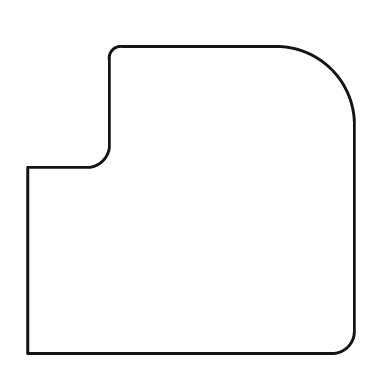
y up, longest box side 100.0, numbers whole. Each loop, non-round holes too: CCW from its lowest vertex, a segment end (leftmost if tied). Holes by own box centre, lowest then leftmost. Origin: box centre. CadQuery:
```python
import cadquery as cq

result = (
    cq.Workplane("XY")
    .moveTo(-50.0, -47.0)
    .lineTo(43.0, -47.0)
    .threePointArc((48.0, -45.0), (50.0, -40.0))
    .lineTo(50.0, 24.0)
    .threePointArc((43.0, 40.0), (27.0, 47.0))
    .lineTo(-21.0, 47.0)
    .threePointArc((-24.0, 46.0), (-25.0, 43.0))
    .lineTo(-25.0, 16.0)
    .threePointArc((-27.0, 12.0), (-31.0, 10.0))
    .lineTo(-50.0, 10.0)
    .close()
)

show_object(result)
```